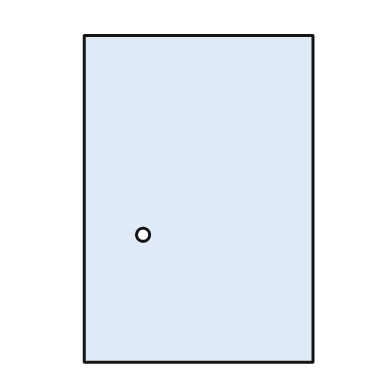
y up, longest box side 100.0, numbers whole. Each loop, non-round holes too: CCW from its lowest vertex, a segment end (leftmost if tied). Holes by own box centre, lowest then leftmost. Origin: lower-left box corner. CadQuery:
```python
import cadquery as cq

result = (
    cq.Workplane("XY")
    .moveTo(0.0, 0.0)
    .lineTo(70.0, 0.0)
    .lineTo(70.0, 100.0)
    .lineTo(0.0, 100.0)
    .close()
    .moveTo(18.0, 39.0)
    .circle(2.0)
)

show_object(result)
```